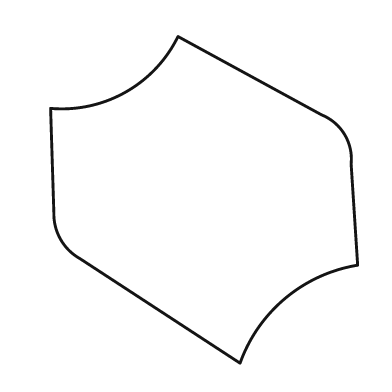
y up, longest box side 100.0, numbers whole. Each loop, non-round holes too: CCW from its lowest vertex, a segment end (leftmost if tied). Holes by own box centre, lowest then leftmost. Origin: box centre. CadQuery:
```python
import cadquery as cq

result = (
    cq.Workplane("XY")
    .moveTo(11.0, -50.0)
    .threePointArc((25.0, -30.0), (47.0, -20.0))
    .lineTo(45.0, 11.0)
    .threePointArc((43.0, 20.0), (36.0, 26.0))
    .lineTo(-8.0, 50.0)
    .threePointArc((-24.0, 33.0), (-47.0, 28.0))
    .lineTo(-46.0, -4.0)
    .threePointArc((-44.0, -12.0), (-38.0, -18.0))
    .close()
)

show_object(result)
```